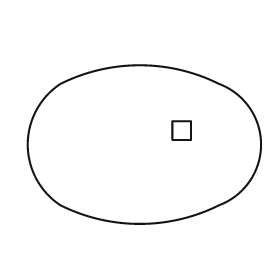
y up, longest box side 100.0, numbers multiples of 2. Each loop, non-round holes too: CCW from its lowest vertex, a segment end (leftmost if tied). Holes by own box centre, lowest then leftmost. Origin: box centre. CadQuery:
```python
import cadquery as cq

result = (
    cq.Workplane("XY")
    .moveTo(-36.0, -26.0)
    .threePointArc((-2.0, -34.0), (32.0, -26.0))
    .threePointArc((50.0, 0.0), (32.0, 26.0))
    .threePointArc((-2.0, 34.0), (-36.0, 26.0))
    .threePointArc((-50.0, 0.0), (-36.0, -26.0))
    .close()
    .moveTo(12.0, 2.0)
    .lineTo(20.0, 2.0)
    .lineTo(20.0, 10.0)
    .lineTo(12.0, 10.0)
    .close()
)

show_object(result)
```